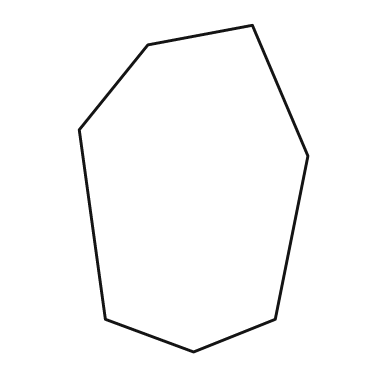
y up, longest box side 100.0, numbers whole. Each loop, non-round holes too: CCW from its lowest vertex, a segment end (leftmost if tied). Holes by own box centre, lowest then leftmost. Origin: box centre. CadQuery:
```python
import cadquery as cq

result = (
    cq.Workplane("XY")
    .moveTo(0.0, -50.0)
    .lineTo(25.0, -40.0)
    .lineTo(35.0, 10.0)
    .lineTo(18.0, 50.0)
    .lineTo(-14.0, 44.0)
    .lineTo(-35.0, 18.0)
    .lineTo(-27.0, -40.0)
    .close()
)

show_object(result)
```